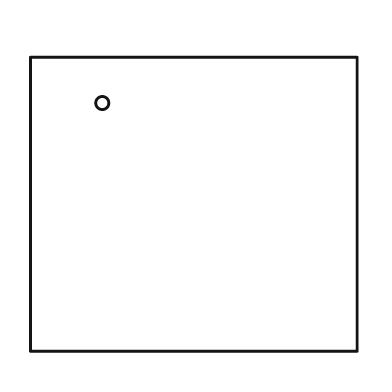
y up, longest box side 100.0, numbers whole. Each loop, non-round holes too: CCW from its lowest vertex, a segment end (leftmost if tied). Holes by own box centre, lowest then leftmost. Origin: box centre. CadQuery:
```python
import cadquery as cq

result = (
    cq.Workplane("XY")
    .moveTo(-50.0, -45.0)
    .lineTo(50.0, -45.0)
    .lineTo(50.0, 45.0)
    .lineTo(-50.0, 45.0)
    .close()
    .moveTo(-28.0, 31.0)
    .circle(2.0)
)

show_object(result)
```